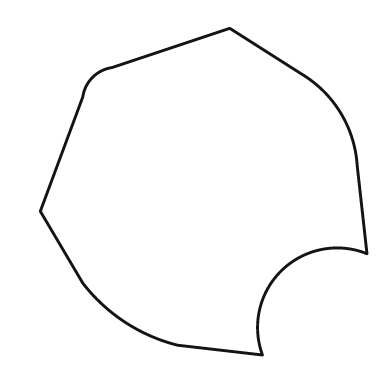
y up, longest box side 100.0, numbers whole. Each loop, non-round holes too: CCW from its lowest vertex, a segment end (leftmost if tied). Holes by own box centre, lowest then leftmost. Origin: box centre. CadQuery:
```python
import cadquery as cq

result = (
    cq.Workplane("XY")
    .moveTo(18.0, -50.0)
    .threePointArc((24.0, -24.0), (50.0, -19.0))
    .lineTo(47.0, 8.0)
    .threePointArc((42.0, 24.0), (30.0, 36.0))
    .lineTo(8.0, 50.0)
    .lineTo(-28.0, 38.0)
    .threePointArc((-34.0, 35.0), (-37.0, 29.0))
    .lineTo(-50.0, -6.0)
    .lineTo(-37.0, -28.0)
    .threePointArc((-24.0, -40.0), (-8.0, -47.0))
    .close()
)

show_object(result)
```